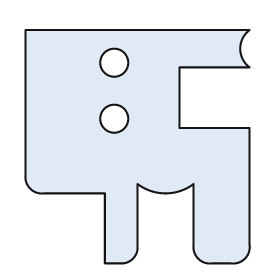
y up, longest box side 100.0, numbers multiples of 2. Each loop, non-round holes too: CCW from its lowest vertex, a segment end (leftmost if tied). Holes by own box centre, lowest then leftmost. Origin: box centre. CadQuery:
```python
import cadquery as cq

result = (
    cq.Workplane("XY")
    .moveTo(-14.0, -50.0)
    .lineTo(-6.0, -50.0)
    .threePointArc((-2.0, -48.0), (0.0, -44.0))
    .lineTo(0.0, -16.0)
    .threePointArc((12.0, -20.0), (24.0, -16.0))
    .lineTo(24.0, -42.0)
    .threePointArc((26.0, -48.0), (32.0, -50.0))
    .lineTo(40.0, -50.0)
    .threePointArc((46.0, -48.0), (48.0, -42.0))
    .lineTo(48.0, 8.0)
    .lineTo(18.0, 8.0)
    .lineTo(18.0, 34.0)
    .lineTo(48.0, 34.0)
    .threePointArc((44.0, 42.0), (48.0, 50.0))
    .lineTo(-48.0, 50.0)
    .lineTo(-48.0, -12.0)
    .threePointArc((-46.0, -18.0), (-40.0, -20.0))
    .lineTo(-14.0, -20.0)
    .close()
    .moveTo(-10.0, 12.0)
    .circle(6.0)
    .moveTo(-10.0, 36.0)
    .circle(6.0)
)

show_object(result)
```